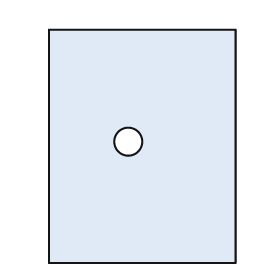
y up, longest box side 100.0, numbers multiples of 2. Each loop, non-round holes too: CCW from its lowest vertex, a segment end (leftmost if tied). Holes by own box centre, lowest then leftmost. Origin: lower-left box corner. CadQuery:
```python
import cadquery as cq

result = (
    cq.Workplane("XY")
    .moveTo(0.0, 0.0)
    .lineTo(80.0, 0.0)
    .lineTo(80.0, 100.0)
    .lineTo(0.0, 100.0)
    .close()
    .moveTo(34.0, 52.0)
    .circle(6.0)
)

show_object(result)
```